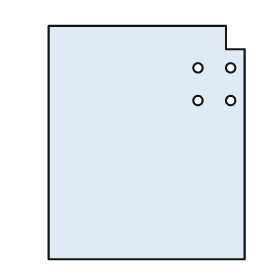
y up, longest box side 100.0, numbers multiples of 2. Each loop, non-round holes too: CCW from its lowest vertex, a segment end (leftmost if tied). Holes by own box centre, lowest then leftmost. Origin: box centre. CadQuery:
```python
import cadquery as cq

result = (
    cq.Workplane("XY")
    .moveTo(-42.0, -50.0)
    .lineTo(42.0, -50.0)
    .lineTo(42.0, 40.0)
    .lineTo(34.0, 40.0)
    .lineTo(34.0, 50.0)
    .lineTo(-42.0, 50.0)
    .close()
    .moveTo(22.0, 18.0)
    .circle(2.0)
    .moveTo(36.0, 18.0)
    .circle(2.0)
    .moveTo(22.0, 32.0)
    .circle(2.0)
    .moveTo(36.0, 32.0)
    .circle(2.0)
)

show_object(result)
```